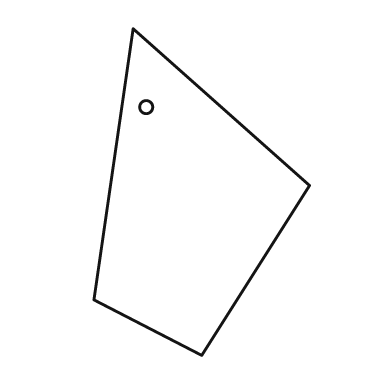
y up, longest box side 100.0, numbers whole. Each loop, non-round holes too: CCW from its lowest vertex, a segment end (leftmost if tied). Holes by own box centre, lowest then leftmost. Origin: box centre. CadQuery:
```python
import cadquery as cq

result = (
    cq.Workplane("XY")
    .moveTo(0.0, -50.0)
    .lineTo(33.0, 2.0)
    .lineTo(-21.0, 50.0)
    .lineTo(-33.0, -33.0)
    .close()
    .moveTo(-17.0, 26.0)
    .circle(2.0)
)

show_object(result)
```